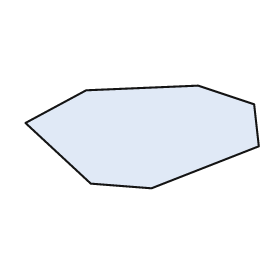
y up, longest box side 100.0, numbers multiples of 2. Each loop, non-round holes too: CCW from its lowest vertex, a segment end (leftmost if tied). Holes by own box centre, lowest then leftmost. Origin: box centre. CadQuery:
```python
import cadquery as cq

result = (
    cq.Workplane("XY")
    .moveTo(4.0, -22.0)
    .lineTo(50.0, -4.0)
    .lineTo(48.0, 14.0)
    .lineTo(24.0, 22.0)
    .lineTo(-24.0, 20.0)
    .lineTo(-50.0, 6.0)
    .lineTo(-22.0, -20.0)
    .close()
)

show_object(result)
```